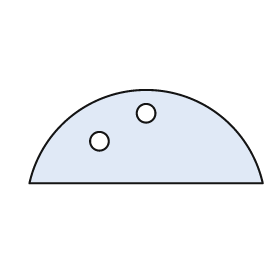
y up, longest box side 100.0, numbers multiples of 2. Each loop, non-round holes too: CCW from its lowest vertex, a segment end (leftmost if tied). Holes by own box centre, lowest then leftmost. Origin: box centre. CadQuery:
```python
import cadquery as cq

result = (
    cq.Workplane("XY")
    .moveTo(-50.0, -20.0)
    .lineTo(50.0, -20.0)
    .threePointArc((0.0, 20.0), (-50.0, -20.0))
    .close()
    .moveTo(-20.0, -2.0)
    .circle(4.0)
    .moveTo(0.0, 10.0)
    .circle(4.0)
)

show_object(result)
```